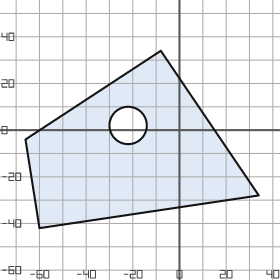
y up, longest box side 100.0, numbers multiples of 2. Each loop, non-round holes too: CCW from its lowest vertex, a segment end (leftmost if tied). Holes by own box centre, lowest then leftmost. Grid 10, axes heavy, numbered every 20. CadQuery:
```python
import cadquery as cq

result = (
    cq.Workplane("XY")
    .moveTo(-60.0, -42.0)
    .lineTo(34.0, -28.0)
    .lineTo(-8.0, 34.0)
    .lineTo(-66.0, -4.0)
    .close()
    .moveTo(-22.0, 2.0)
    .circle(8.0)
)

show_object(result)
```